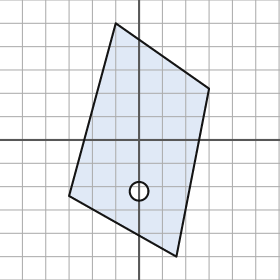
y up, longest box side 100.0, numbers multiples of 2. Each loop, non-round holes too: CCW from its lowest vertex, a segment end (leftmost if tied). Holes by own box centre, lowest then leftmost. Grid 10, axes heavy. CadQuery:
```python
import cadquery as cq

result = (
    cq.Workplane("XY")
    .moveTo(16.0, -50.0)
    .lineTo(30.0, 22.0)
    .lineTo(-10.0, 50.0)
    .lineTo(-30.0, -24.0)
    .close()
    .moveTo(0.0, -22.0)
    .circle(4.0)
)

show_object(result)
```